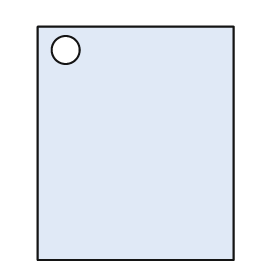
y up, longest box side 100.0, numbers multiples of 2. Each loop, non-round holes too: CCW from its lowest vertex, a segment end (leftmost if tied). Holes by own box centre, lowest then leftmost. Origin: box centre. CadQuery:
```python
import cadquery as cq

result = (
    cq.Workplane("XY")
    .moveTo(-42.0, -50.0)
    .lineTo(42.0, -50.0)
    .lineTo(42.0, 50.0)
    .lineTo(-42.0, 50.0)
    .close()
    .moveTo(-30.0, 40.0)
    .circle(6.0)
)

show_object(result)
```